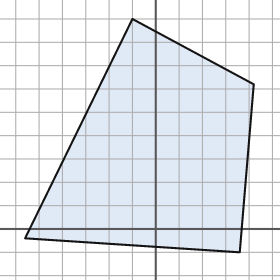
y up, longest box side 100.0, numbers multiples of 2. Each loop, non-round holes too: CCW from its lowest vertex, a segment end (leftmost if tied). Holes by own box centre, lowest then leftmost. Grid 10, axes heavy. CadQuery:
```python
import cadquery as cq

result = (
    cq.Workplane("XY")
    .moveTo(36.0, -10.0)
    .lineTo(42.0, 62.0)
    .lineTo(-10.0, 90.0)
    .lineTo(-56.0, -4.0)
    .close()
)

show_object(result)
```